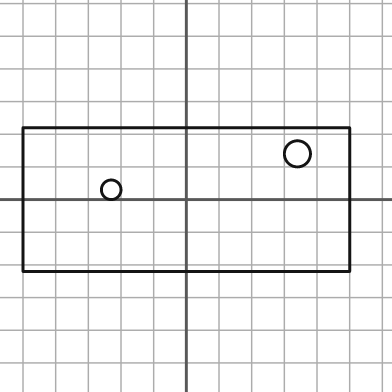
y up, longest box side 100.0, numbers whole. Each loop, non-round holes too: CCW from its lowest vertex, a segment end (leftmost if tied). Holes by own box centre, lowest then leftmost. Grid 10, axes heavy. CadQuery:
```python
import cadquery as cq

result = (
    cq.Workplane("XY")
    .moveTo(-50.0, -22.0)
    .lineTo(50.0, -22.0)
    .lineTo(50.0, 22.0)
    .lineTo(-50.0, 22.0)
    .close()
    .moveTo(-23.0, 3.0)
    .circle(3.0)
    .moveTo(34.0, 14.0)
    .circle(4.0)
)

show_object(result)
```